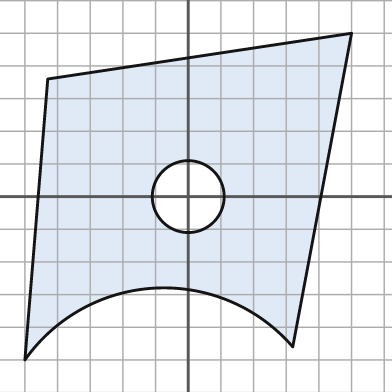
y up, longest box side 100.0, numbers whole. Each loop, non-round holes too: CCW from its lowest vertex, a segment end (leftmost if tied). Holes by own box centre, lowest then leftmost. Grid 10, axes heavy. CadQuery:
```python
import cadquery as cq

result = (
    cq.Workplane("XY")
    .moveTo(-50.0, -50.0)
    .threePointArc((-10.0, -28.0), (32.0, -46.0))
    .lineTo(50.0, 50.0)
    .lineTo(-43.0, 36.0)
    .close()
    .moveTo(0.0, 0.0)
    .circle(11.0)
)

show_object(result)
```